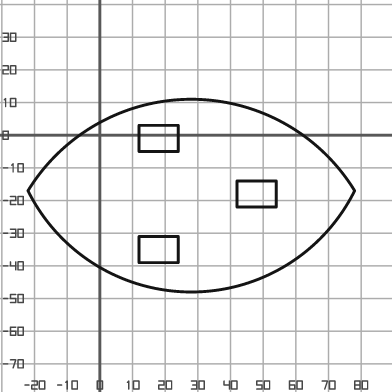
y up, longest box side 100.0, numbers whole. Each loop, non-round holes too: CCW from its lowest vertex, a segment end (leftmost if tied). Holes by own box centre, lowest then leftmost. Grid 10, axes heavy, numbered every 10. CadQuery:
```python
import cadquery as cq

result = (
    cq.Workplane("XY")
    .moveTo(-22.0, -17.0)
    .threePointArc((28.0, -48.0), (78.0, -17.0))
    .threePointArc((28.0, 11.0), (-22.0, -17.0))
    .close()
    .moveTo(12.0, -39.0)
    .lineTo(24.0, -39.0)
    .lineTo(24.0, -31.0)
    .lineTo(12.0, -31.0)
    .close()
    .moveTo(42.0, -22.0)
    .lineTo(54.0, -22.0)
    .lineTo(54.0, -14.0)
    .lineTo(42.0, -14.0)
    .close()
    .moveTo(12.0, -5.0)
    .lineTo(24.0, -5.0)
    .lineTo(24.0, 3.0)
    .lineTo(12.0, 3.0)
    .close()
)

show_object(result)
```